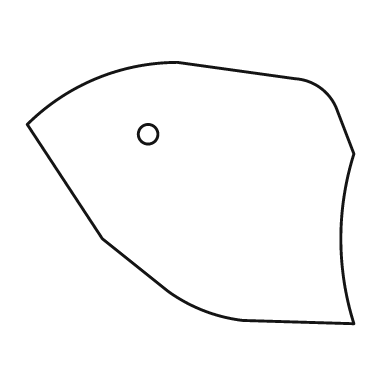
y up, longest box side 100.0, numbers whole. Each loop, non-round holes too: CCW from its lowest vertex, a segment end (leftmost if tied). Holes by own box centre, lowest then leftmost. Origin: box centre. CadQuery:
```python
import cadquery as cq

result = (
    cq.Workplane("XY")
    .moveTo(50.0, -40.0)
    .threePointArc((46.0, -14.0), (50.0, 12.0))
    .lineTo(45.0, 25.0)
    .threePointArc((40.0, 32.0), (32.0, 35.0))
    .lineTo(-4.0, 40.0)
    .threePointArc((-29.0, 35.0), (-50.0, 21.0))
    .lineTo(-27.0, -14.0)
    .lineTo(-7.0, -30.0)
    .threePointArc((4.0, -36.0), (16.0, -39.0))
    .close()
    .moveTo(-13.0, 18.0)
    .circle(3.0)
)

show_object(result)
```